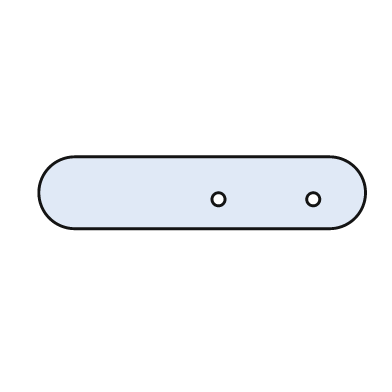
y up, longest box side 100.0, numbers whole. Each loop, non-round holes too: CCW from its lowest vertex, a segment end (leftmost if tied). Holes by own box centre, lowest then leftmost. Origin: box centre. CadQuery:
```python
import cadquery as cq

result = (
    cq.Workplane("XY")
    .moveTo(-39.0, -11.0)
    .lineTo(39.0, -11.0)
    .threePointArc((50.0, 0.0), (39.0, 11.0))
    .lineTo(-39.0, 11.0)
    .threePointArc((-50.0, 0.0), (-39.0, -11.0))
    .close()
    .moveTo(5.0, -2.0)
    .circle(2.0)
    .moveTo(34.0, -2.0)
    .circle(2.0)
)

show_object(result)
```